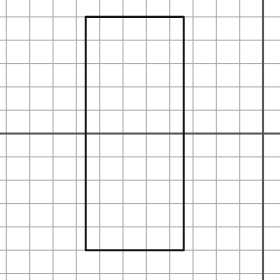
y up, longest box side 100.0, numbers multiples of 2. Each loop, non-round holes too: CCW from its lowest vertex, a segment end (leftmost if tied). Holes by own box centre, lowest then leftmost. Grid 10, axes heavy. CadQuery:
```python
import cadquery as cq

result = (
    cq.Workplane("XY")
    .moveTo(-76.0, -50.0)
    .lineTo(-34.0, -50.0)
    .lineTo(-34.0, 50.0)
    .lineTo(-76.0, 50.0)
    .close()
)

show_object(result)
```